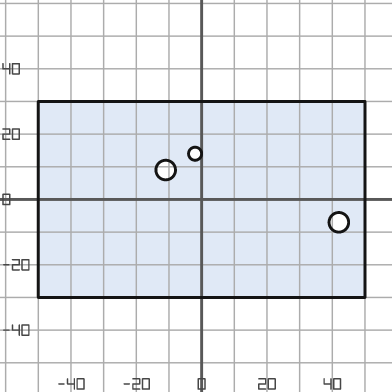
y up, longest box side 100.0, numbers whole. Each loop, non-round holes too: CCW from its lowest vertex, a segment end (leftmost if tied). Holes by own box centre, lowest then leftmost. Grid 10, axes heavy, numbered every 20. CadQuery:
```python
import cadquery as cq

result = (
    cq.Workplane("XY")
    .moveTo(-50.0, -30.0)
    .lineTo(50.0, -30.0)
    .lineTo(50.0, 30.0)
    .lineTo(-50.0, 30.0)
    .close()
    .moveTo(42.0, -7.0)
    .circle(3.0)
    .moveTo(-11.0, 9.0)
    .circle(3.0)
    .moveTo(-2.0, 14.0)
    .circle(2.0)
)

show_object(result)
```